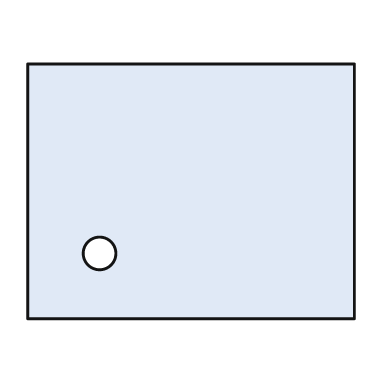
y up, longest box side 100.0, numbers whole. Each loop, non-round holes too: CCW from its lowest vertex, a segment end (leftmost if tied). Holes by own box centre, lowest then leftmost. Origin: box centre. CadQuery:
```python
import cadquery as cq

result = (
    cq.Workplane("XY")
    .moveTo(-50.0, -39.0)
    .lineTo(50.0, -39.0)
    .lineTo(50.0, 39.0)
    .lineTo(-50.0, 39.0)
    .close()
    .moveTo(-28.0, -19.0)
    .circle(5.0)
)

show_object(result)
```